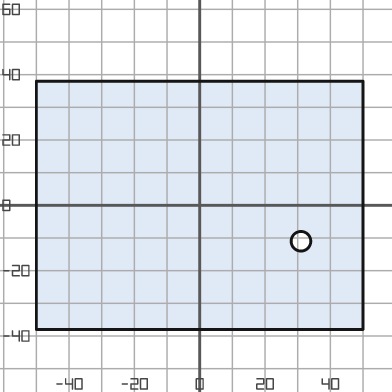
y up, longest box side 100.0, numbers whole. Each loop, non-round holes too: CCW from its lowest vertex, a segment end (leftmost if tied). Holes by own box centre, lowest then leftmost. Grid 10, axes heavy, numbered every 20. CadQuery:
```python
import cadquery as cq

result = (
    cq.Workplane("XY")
    .moveTo(-50.0, -38.0)
    .lineTo(50.0, -38.0)
    .lineTo(50.0, 38.0)
    .lineTo(-50.0, 38.0)
    .close()
    .moveTo(31.0, -11.0)
    .circle(3.0)
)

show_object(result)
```